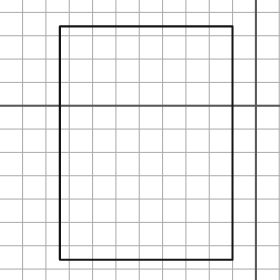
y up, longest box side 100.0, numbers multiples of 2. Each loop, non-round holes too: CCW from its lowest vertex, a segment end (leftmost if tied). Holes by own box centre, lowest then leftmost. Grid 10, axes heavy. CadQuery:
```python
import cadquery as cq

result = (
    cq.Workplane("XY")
    .moveTo(-84.0, -66.0)
    .lineTo(-10.0, -66.0)
    .lineTo(-10.0, 34.0)
    .lineTo(-84.0, 34.0)
    .close()
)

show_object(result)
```